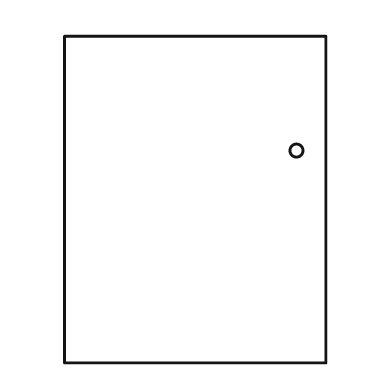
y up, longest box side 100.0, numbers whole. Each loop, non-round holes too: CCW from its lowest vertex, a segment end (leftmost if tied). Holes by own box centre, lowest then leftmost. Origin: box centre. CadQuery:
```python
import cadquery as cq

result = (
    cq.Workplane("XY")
    .moveTo(-40.0, -50.0)
    .lineTo(40.0, -50.0)
    .lineTo(40.0, 50.0)
    .lineTo(-40.0, 50.0)
    .close()
    .moveTo(31.0, 15.0)
    .circle(2.0)
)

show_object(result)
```